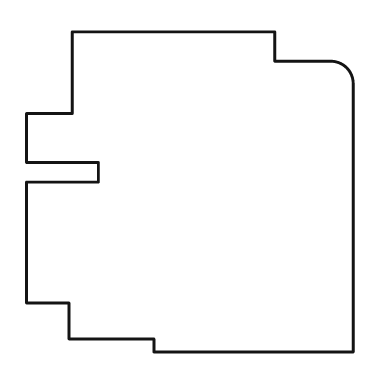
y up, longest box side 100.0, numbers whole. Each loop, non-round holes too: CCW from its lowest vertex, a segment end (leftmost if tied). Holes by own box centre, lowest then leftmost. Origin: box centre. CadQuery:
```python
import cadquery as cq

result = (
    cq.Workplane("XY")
    .moveTo(-11.0, -49.0)
    .lineTo(50.0, -49.0)
    .lineTo(50.0, 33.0)
    .threePointArc((48.0, 38.0), (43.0, 40.0))
    .lineTo(26.0, 40.0)
    .lineTo(26.0, 49.0)
    .lineTo(-36.0, 49.0)
    .lineTo(-36.0, 24.0)
    .lineTo(-50.0, 24.0)
    .lineTo(-50.0, 9.0)
    .lineTo(-28.0, 9.0)
    .lineTo(-28.0, 3.0)
    .lineTo(-50.0, 3.0)
    .lineTo(-50.0, -34.0)
    .lineTo(-37.0, -34.0)
    .lineTo(-37.0, -45.0)
    .lineTo(-11.0, -45.0)
    .close()
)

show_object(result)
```